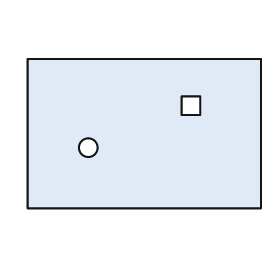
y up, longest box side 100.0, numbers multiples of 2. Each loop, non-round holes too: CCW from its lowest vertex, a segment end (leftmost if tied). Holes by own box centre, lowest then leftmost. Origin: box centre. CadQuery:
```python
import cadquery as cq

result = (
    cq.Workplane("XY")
    .moveTo(-50.0, -32.0)
    .lineTo(50.0, -32.0)
    .lineTo(50.0, 32.0)
    .lineTo(-50.0, 32.0)
    .close()
    .moveTo(-24.0, -6.0)
    .circle(4.0)
    .moveTo(16.0, 8.0)
    .lineTo(24.0, 8.0)
    .lineTo(24.0, 16.0)
    .lineTo(16.0, 16.0)
    .close()
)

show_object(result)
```